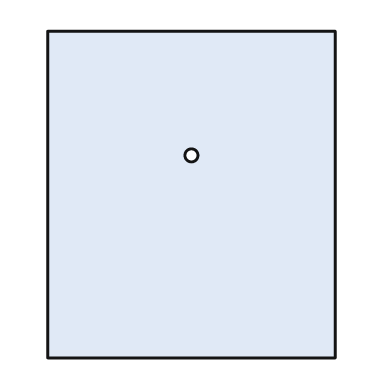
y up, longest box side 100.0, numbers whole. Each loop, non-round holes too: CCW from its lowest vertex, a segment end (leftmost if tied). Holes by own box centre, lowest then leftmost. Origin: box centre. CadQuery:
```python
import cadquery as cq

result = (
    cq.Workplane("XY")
    .moveTo(-44.0, -50.0)
    .lineTo(44.0, -50.0)
    .lineTo(44.0, 50.0)
    .lineTo(-44.0, 50.0)
    .close()
    .moveTo(0.0, 12.0)
    .circle(2.0)
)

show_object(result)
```